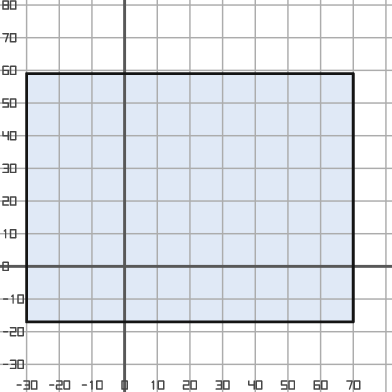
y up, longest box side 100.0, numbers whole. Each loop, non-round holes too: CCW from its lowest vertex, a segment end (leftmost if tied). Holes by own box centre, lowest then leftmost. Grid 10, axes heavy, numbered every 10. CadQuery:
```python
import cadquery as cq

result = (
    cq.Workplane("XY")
    .moveTo(-30.0, -17.0)
    .lineTo(70.0, -17.0)
    .lineTo(70.0, 59.0)
    .lineTo(-30.0, 59.0)
    .close()
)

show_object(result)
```